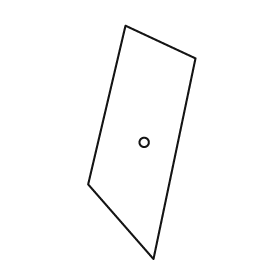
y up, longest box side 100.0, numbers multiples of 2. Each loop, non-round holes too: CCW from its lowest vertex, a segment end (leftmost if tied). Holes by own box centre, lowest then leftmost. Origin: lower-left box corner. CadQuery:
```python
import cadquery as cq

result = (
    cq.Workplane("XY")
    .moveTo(28.0, 0.0)
    .lineTo(46.0, 86.0)
    .lineTo(16.0, 100.0)
    .lineTo(0.0, 32.0)
    .close()
    .moveTo(24.0, 50.0)
    .circle(2.0)
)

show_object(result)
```